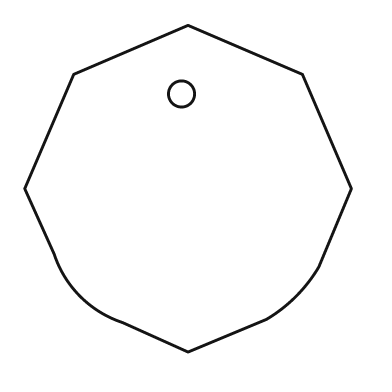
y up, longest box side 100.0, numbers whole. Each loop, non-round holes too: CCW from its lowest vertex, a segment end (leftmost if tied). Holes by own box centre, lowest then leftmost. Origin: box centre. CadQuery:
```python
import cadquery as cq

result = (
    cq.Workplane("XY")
    .moveTo(0.0, -50.0)
    .lineTo(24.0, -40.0)
    .threePointArc((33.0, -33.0), (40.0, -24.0))
    .lineTo(50.0, 0.0)
    .lineTo(35.0, 35.0)
    .lineTo(0.0, 50.0)
    .lineTo(-35.0, 35.0)
    .lineTo(-50.0, 0.0)
    .lineTo(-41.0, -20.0)
    .threePointArc((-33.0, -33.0), (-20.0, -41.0))
    .close()
    .moveTo(-2.0, 29.0)
    .circle(4.0)
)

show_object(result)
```